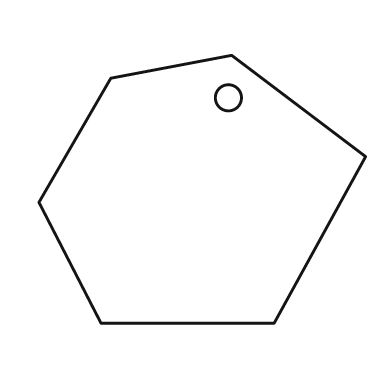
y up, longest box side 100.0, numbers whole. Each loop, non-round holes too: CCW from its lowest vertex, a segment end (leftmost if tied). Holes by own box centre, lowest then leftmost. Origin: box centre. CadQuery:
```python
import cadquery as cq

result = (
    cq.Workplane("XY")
    .moveTo(-31.0, -41.0)
    .lineTo(22.0, -41.0)
    .lineTo(50.0, 10.0)
    .lineTo(9.0, 41.0)
    .lineTo(-28.0, 34.0)
    .lineTo(-50.0, -4.0)
    .close()
    .moveTo(8.0, 28.0)
    .circle(4.0)
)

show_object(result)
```